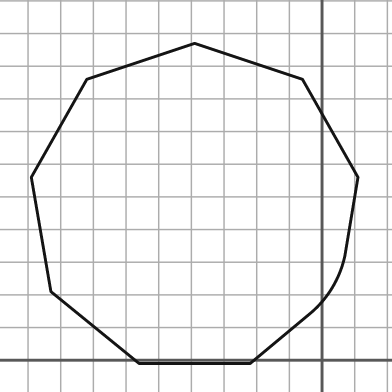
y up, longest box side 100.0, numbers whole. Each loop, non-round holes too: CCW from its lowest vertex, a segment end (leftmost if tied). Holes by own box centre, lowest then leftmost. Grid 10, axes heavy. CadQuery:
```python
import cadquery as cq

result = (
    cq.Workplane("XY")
    .moveTo(-56.0, -1.0)
    .lineTo(-22.0, -1.0)
    .lineTo(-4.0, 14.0)
    .threePointArc((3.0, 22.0), (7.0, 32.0))
    .lineTo(11.0, 56.0)
    .lineTo(-6.0, 86.0)
    .lineTo(-39.0, 97.0)
    .lineTo(-72.0, 86.0)
    .lineTo(-89.0, 56.0)
    .lineTo(-83.0, 21.0)
    .close()
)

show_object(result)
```